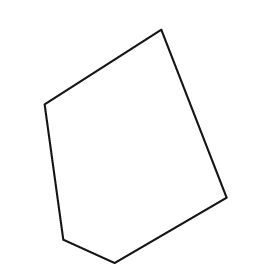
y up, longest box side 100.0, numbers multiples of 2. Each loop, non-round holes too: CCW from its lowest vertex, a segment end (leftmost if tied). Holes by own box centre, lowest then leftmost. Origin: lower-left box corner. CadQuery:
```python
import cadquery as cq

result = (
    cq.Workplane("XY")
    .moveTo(30.0, 0.0)
    .lineTo(78.0, 28.0)
    .lineTo(50.0, 100.0)
    .lineTo(0.0, 68.0)
    .lineTo(8.0, 10.0)
    .close()
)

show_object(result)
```